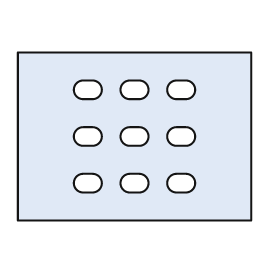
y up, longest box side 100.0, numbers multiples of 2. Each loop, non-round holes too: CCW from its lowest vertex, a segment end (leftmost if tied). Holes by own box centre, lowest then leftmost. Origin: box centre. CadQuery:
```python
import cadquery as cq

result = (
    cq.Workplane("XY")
    .moveTo(-50.0, -36.0)
    .lineTo(50.0, -36.0)
    .lineTo(50.0, 36.0)
    .lineTo(-50.0, 36.0)
    .close()
    .moveTo(-22.0, -24.0)
    .lineTo(-18.0, -24.0)
    .threePointArc((-14.0, -20.0), (-18.0, -16.0))
    .lineTo(-22.0, -16.0)
    .threePointArc((-26.0, -20.0), (-22.0, -24.0))
    .close()
    .moveTo(-2.0, -24.0)
    .lineTo(2.0, -24.0)
    .threePointArc((6.0, -20.0), (2.0, -16.0))
    .lineTo(-2.0, -16.0)
    .threePointArc((-6.0, -20.0), (-2.0, -24.0))
    .close()
    .moveTo(18.0, -24.0)
    .lineTo(22.0, -24.0)
    .threePointArc((26.0, -20.0), (22.0, -16.0))
    .lineTo(18.0, -16.0)
    .threePointArc((14.0, -20.0), (18.0, -24.0))
    .close()
    .moveTo(-22.0, -4.0)
    .lineTo(-18.0, -4.0)
    .threePointArc((-14.0, 0.0), (-18.0, 4.0))
    .lineTo(-22.0, 4.0)
    .threePointArc((-26.0, 0.0), (-22.0, -4.0))
    .close()
    .moveTo(-2.0, -4.0)
    .lineTo(2.0, -4.0)
    .threePointArc((6.0, 0.0), (2.0, 4.0))
    .lineTo(-2.0, 4.0)
    .threePointArc((-6.0, 0.0), (-2.0, -4.0))
    .close()
    .moveTo(18.0, -4.0)
    .lineTo(22.0, -4.0)
    .threePointArc((26.0, 0.0), (22.0, 4.0))
    .lineTo(18.0, 4.0)
    .threePointArc((14.0, 0.0), (18.0, -4.0))
    .close()
    .moveTo(-22.0, 16.0)
    .lineTo(-18.0, 16.0)
    .threePointArc((-14.0, 20.0), (-18.0, 24.0))
    .lineTo(-22.0, 24.0)
    .threePointArc((-26.0, 20.0), (-22.0, 16.0))
    .close()
    .moveTo(-2.0, 16.0)
    .lineTo(2.0, 16.0)
    .threePointArc((6.0, 20.0), (2.0, 24.0))
    .lineTo(-2.0, 24.0)
    .threePointArc((-6.0, 20.0), (-2.0, 16.0))
    .close()
    .moveTo(18.0, 16.0)
    .lineTo(22.0, 16.0)
    .threePointArc((26.0, 20.0), (22.0, 24.0))
    .lineTo(18.0, 24.0)
    .threePointArc((14.0, 20.0), (18.0, 16.0))
    .close()
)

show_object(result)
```